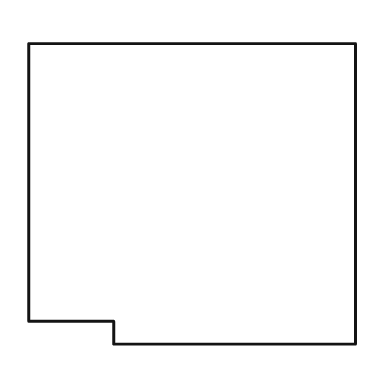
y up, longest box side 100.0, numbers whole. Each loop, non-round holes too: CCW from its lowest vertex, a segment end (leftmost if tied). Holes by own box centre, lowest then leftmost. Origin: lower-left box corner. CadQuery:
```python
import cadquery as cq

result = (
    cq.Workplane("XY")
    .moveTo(26.0, 0.0)
    .lineTo(100.0, 0.0)
    .lineTo(100.0, 92.0)
    .lineTo(0.0, 92.0)
    .lineTo(0.0, 7.0)
    .lineTo(26.0, 7.0)
    .close()
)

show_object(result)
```